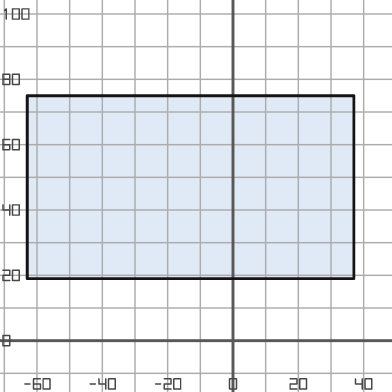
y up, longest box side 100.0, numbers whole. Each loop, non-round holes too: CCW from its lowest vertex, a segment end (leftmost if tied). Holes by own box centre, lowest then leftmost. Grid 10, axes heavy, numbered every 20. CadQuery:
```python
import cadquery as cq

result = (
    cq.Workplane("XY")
    .moveTo(-63.0, 19.0)
    .lineTo(37.0, 19.0)
    .lineTo(37.0, 75.0)
    .lineTo(-63.0, 75.0)
    .close()
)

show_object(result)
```